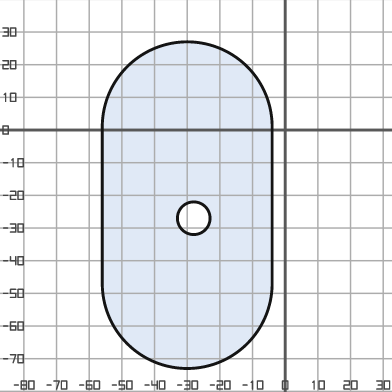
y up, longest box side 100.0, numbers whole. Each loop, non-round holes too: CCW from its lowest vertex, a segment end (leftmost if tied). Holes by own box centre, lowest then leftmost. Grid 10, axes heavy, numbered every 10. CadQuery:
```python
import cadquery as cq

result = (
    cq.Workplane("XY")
    .moveTo(-56.0, -47.0)
    .threePointArc((-30.0, -73.0), (-4.0, -47.0))
    .lineTo(-4.0, 1.0)
    .threePointArc((-30.0, 27.0), (-56.0, 1.0))
    .close()
    .moveTo(-28.0, -27.0)
    .circle(5.0)
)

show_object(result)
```